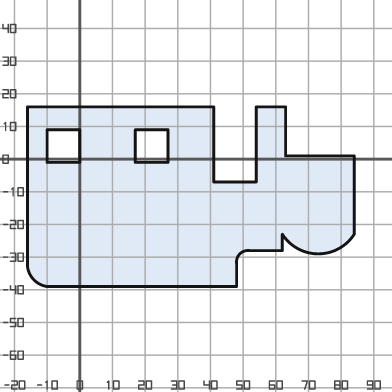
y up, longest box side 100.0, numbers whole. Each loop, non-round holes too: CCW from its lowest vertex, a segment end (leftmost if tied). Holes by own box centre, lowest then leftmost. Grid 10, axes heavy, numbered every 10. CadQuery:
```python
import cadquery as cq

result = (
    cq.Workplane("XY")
    .moveTo(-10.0, -39.0)
    .lineTo(48.0, -39.0)
    .lineTo(48.0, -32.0)
    .threePointArc((49.0, -29.0), (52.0, -28.0))
    .lineTo(62.0, -28.0)
    .lineTo(62.0, -23.0)
    .threePointArc((73.0, -29.0), (84.0, -23.0))
    .lineTo(84.0, 1.0)
    .lineTo(63.0, 1.0)
    .lineTo(63.0, 16.0)
    .lineTo(54.0, 16.0)
    .lineTo(54.0, -7.0)
    .lineTo(41.0, -7.0)
    .lineTo(41.0, 16.0)
    .lineTo(-16.0, 16.0)
    .lineTo(-16.0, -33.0)
    .threePointArc((-14.0, -37.0), (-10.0, -39.0))
    .close()
    .moveTo(-10.0, -1.0)
    .lineTo(0.0, -1.0)
    .lineTo(0.0, 9.0)
    .lineTo(-10.0, 9.0)
    .close()
    .moveTo(17.0, -1.0)
    .lineTo(27.0, -1.0)
    .lineTo(27.0, 9.0)
    .lineTo(17.0, 9.0)
    .close()
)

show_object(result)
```